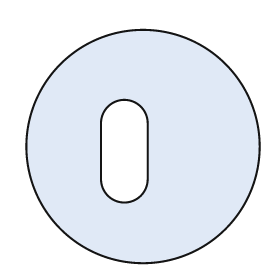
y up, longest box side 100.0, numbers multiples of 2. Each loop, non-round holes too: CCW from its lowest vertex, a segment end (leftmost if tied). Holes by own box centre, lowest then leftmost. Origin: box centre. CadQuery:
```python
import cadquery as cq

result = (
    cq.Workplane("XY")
    .moveTo(0.0, 0.0)
    .circle(50.0)
    .moveTo(-18.0, -14.0)
    .threePointArc((-8.0, -24.0), (2.0, -14.0))
    .lineTo(2.0, 10.0)
    .threePointArc((-8.0, 20.0), (-18.0, 10.0))
    .close()
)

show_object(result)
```